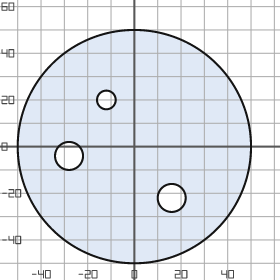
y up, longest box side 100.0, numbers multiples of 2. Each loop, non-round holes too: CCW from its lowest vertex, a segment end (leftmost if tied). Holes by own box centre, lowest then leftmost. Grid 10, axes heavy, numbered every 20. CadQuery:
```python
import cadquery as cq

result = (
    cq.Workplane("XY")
    .moveTo(0.0, 0.0)
    .circle(50.0)
    .moveTo(16.0, -22.0)
    .circle(6.0)
    .moveTo(-28.0, -4.0)
    .circle(6.0)
    .moveTo(-12.0, 20.0)
    .circle(4.0)
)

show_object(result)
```